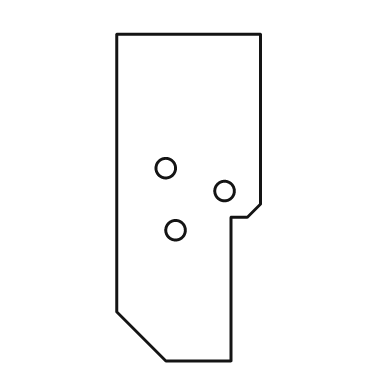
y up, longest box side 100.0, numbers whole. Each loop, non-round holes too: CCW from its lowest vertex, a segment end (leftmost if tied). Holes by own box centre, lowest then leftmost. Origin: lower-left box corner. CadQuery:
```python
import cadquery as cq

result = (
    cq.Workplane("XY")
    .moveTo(15.0, 0.0)
    .lineTo(35.0, 0.0)
    .lineTo(35.0, 44.0)
    .lineTo(40.0, 44.0)
    .lineTo(44.0, 48.0)
    .lineTo(44.0, 100.0)
    .lineTo(0.0, 100.0)
    .lineTo(0.0, 15.0)
    .close()
    .moveTo(18.0, 40.0)
    .circle(3.0)
    .moveTo(33.0, 52.0)
    .circle(3.0)
    .moveTo(15.0, 59.0)
    .circle(3.0)
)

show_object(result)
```